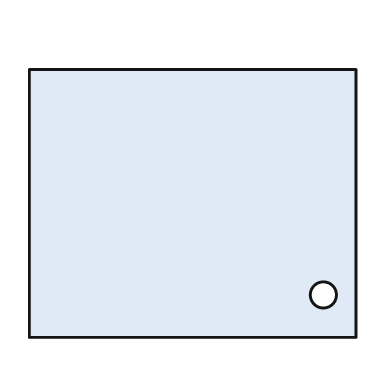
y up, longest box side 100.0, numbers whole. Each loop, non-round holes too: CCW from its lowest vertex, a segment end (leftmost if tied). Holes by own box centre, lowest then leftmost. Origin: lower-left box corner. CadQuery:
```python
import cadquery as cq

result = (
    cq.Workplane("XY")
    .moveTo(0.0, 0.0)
    .lineTo(100.0, 0.0)
    .lineTo(100.0, 82.0)
    .lineTo(0.0, 82.0)
    .close()
    .moveTo(90.0, 13.0)
    .circle(4.0)
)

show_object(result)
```